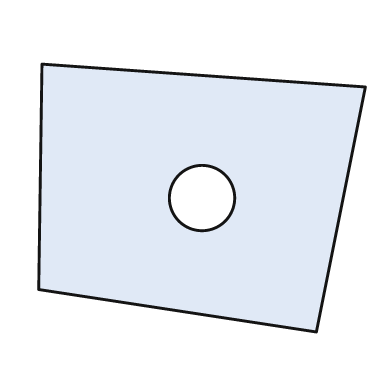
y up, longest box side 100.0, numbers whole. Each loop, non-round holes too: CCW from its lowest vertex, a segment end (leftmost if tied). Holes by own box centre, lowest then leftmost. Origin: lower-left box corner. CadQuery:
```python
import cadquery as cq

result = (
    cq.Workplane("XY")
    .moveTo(85.0, 0.0)
    .lineTo(100.0, 75.0)
    .lineTo(1.0, 82.0)
    .lineTo(0.0, 13.0)
    .close()
    .moveTo(50.0, 41.0)
    .circle(10.0)
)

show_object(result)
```